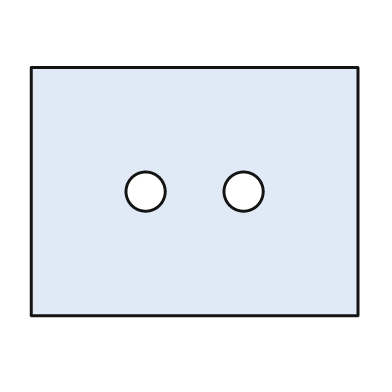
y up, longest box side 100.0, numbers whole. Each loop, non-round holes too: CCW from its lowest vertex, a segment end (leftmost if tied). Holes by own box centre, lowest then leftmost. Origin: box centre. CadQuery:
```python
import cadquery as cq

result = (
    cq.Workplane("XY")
    .moveTo(-50.0, -38.0)
    .lineTo(50.0, -38.0)
    .lineTo(50.0, 38.0)
    .lineTo(-50.0, 38.0)
    .close()
    .moveTo(-15.0, 0.0)
    .circle(6.0)
    .moveTo(15.0, 0.0)
    .circle(6.0)
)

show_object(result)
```